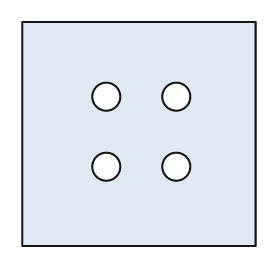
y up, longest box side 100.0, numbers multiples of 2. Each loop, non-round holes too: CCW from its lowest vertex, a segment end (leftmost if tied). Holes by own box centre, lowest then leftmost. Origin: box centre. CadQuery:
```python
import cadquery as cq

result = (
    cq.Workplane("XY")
    .moveTo(-50.0, -48.0)
    .lineTo(50.0, -48.0)
    .lineTo(50.0, 48.0)
    .lineTo(-50.0, 48.0)
    .close()
    .moveTo(-14.0, -14.0)
    .circle(6.0)
    .moveTo(16.0, -14.0)
    .circle(6.0)
    .moveTo(-14.0, 16.0)
    .circle(6.0)
    .moveTo(16.0, 16.0)
    .circle(6.0)
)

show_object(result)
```